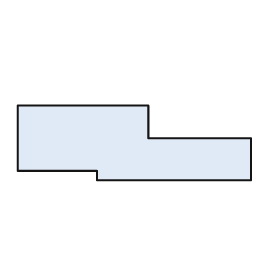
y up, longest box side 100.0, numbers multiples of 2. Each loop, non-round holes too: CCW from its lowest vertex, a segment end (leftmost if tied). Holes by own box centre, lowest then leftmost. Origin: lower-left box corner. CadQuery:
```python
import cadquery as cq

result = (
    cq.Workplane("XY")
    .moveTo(34.0, 0.0)
    .lineTo(100.0, 0.0)
    .lineTo(100.0, 18.0)
    .lineTo(56.0, 18.0)
    .lineTo(56.0, 32.0)
    .lineTo(0.0, 32.0)
    .lineTo(0.0, 4.0)
    .lineTo(34.0, 4.0)
    .close()
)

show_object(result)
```